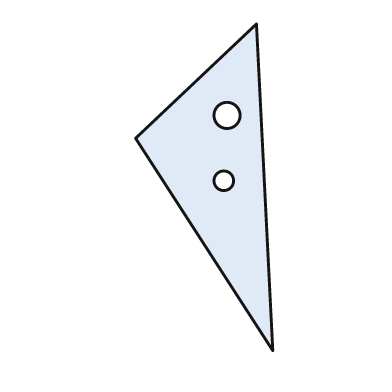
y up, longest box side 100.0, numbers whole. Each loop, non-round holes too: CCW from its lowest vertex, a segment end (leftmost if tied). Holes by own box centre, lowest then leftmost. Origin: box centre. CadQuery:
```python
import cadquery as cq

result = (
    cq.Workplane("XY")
    .moveTo(21.0, -50.0)
    .lineTo(16.0, 50.0)
    .lineTo(-21.0, 15.0)
    .close()
    .moveTo(6.0, 2.0)
    .circle(3.0)
    .moveTo(7.0, 22.0)
    .circle(4.0)
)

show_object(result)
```